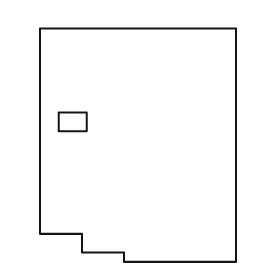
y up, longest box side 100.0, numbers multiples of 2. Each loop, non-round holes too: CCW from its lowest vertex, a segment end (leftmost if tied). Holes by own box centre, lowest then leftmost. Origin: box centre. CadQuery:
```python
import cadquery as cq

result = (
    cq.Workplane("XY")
    .moveTo(-6.0, -50.0)
    .lineTo(42.0, -50.0)
    .lineTo(42.0, 50.0)
    .lineTo(-42.0, 50.0)
    .lineTo(-42.0, -38.0)
    .lineTo(-24.0, -38.0)
    .lineTo(-24.0, -46.0)
    .lineTo(-6.0, -46.0)
    .close()
    .moveTo(-34.0, 6.0)
    .lineTo(-22.0, 6.0)
    .lineTo(-22.0, 14.0)
    .lineTo(-34.0, 14.0)
    .close()
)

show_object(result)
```